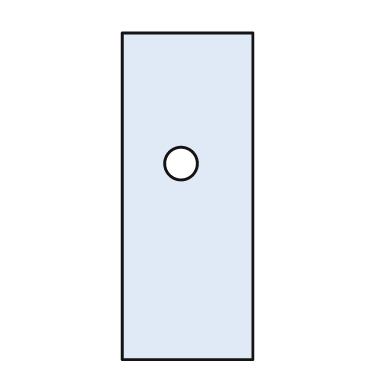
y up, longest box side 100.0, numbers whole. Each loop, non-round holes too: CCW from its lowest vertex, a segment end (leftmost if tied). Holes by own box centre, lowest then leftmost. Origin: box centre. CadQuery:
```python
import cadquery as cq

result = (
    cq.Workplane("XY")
    .moveTo(-20.0, -50.0)
    .lineTo(20.0, -50.0)
    .lineTo(20.0, 50.0)
    .lineTo(-20.0, 50.0)
    .close()
    .moveTo(-2.0, 10.0)
    .circle(5.0)
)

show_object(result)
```